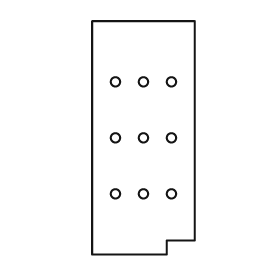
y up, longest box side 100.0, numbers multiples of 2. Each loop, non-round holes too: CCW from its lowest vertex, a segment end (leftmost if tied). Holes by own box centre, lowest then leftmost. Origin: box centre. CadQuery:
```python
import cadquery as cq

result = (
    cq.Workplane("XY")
    .moveTo(-22.0, -50.0)
    .lineTo(10.0, -50.0)
    .lineTo(10.0, -44.0)
    .lineTo(22.0, -44.0)
    .lineTo(22.0, 50.0)
    .lineTo(-22.0, 50.0)
    .close()
    .moveTo(-12.0, -24.0)
    .circle(2.0)
    .moveTo(0.0, -24.0)
    .circle(2.0)
    .moveTo(12.0, -24.0)
    .circle(2.0)
    .moveTo(-12.0, 0.0)
    .circle(2.0)
    .moveTo(0.0, 0.0)
    .circle(2.0)
    .moveTo(12.0, 0.0)
    .circle(2.0)
    .moveTo(-12.0, 24.0)
    .circle(2.0)
    .moveTo(0.0, 24.0)
    .circle(2.0)
    .moveTo(12.0, 24.0)
    .circle(2.0)
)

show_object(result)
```